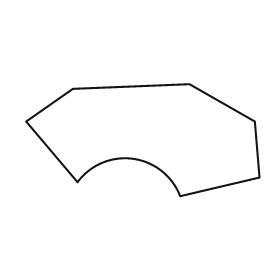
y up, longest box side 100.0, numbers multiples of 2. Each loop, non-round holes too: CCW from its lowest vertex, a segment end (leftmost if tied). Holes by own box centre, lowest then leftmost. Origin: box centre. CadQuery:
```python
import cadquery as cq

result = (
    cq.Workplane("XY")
    .moveTo(16.0, -24.0)
    .lineTo(50.0, -16.0)
    .lineTo(48.0, 8.0)
    .lineTo(20.0, 24.0)
    .lineTo(-30.0, 22.0)
    .lineTo(-50.0, 8.0)
    .lineTo(-28.0, -18.0)
    .threePointArc((-4.0, -8.0), (16.0, -24.0))
    .close()
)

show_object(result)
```